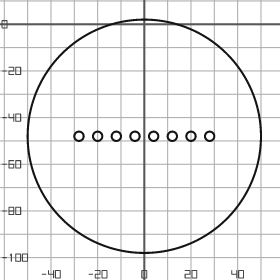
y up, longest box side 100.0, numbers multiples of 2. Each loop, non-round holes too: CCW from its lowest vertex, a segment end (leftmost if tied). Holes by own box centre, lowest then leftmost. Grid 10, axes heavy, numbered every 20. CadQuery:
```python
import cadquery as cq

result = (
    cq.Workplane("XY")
    .moveTo(0.0, -48.0)
    .circle(50.0)
    .moveTo(-28.0, -48.0)
    .circle(2.0)
    .moveTo(-20.0, -48.0)
    .circle(2.0)
    .moveTo(-12.0, -48.0)
    .circle(2.0)
    .moveTo(-4.0, -48.0)
    .circle(2.0)
    .moveTo(4.0, -48.0)
    .circle(2.0)
    .moveTo(12.0, -48.0)
    .circle(2.0)
    .moveTo(20.0, -48.0)
    .circle(2.0)
    .moveTo(28.0, -48.0)
    .circle(2.0)
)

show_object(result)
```